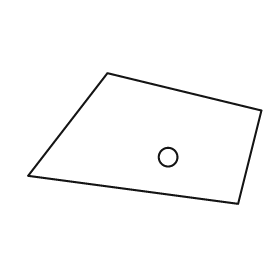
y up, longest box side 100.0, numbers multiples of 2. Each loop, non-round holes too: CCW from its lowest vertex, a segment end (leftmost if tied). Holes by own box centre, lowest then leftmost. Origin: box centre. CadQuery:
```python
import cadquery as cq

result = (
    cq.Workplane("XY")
    .moveTo(40.0, -28.0)
    .lineTo(50.0, 12.0)
    .lineTo(-16.0, 28.0)
    .lineTo(-50.0, -16.0)
    .close()
    .moveTo(10.0, -8.0)
    .circle(4.0)
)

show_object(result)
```